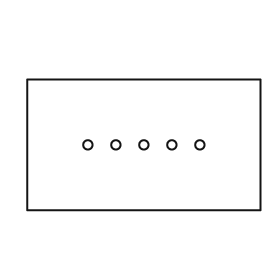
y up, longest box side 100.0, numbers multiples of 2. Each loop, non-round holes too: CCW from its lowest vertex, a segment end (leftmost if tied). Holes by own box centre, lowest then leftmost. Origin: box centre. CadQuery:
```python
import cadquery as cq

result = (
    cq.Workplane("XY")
    .moveTo(-50.0, -28.0)
    .lineTo(50.0, -28.0)
    .lineTo(50.0, 28.0)
    .lineTo(-50.0, 28.0)
    .close()
    .moveTo(-24.0, 0.0)
    .circle(2.0)
    .moveTo(-12.0, 0.0)
    .circle(2.0)
    .moveTo(0.0, 0.0)
    .circle(2.0)
    .moveTo(12.0, 0.0)
    .circle(2.0)
    .moveTo(24.0, 0.0)
    .circle(2.0)
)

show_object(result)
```